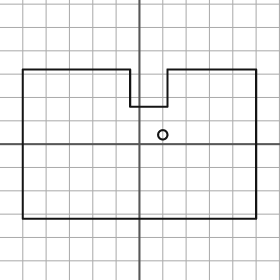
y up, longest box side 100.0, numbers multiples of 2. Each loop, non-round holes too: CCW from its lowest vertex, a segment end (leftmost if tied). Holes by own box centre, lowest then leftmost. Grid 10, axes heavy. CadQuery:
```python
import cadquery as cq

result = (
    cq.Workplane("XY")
    .moveTo(-50.0, -32.0)
    .lineTo(50.0, -32.0)
    .lineTo(50.0, 32.0)
    .lineTo(12.0, 32.0)
    .lineTo(12.0, 16.0)
    .lineTo(-4.0, 16.0)
    .lineTo(-4.0, 32.0)
    .lineTo(-50.0, 32.0)
    .close()
    .moveTo(10.0, 4.0)
    .circle(2.0)
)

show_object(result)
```